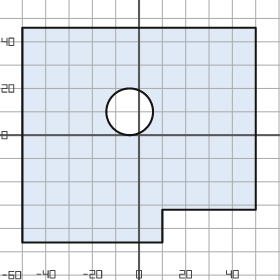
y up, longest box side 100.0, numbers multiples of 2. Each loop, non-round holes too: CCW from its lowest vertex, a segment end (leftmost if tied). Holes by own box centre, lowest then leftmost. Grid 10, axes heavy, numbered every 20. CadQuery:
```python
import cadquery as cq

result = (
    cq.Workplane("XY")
    .moveTo(-50.0, -46.0)
    .lineTo(10.0, -46.0)
    .lineTo(10.0, -32.0)
    .lineTo(50.0, -32.0)
    .lineTo(50.0, 46.0)
    .lineTo(-50.0, 46.0)
    .close()
    .moveTo(-4.0, 10.0)
    .circle(10.0)
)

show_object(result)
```